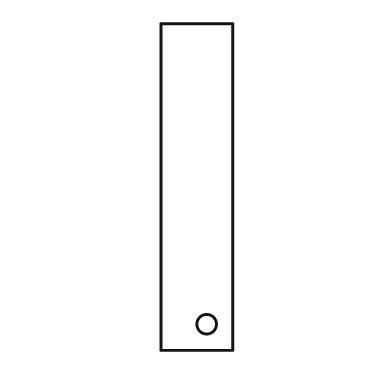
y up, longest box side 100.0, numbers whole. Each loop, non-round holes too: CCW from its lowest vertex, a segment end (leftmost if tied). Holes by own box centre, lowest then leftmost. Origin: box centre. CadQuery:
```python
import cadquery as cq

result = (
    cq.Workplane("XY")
    .moveTo(-11.0, -50.0)
    .lineTo(11.0, -50.0)
    .lineTo(11.0, 50.0)
    .lineTo(-11.0, 50.0)
    .close()
    .moveTo(3.0, -42.0)
    .circle(3.0)
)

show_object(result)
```